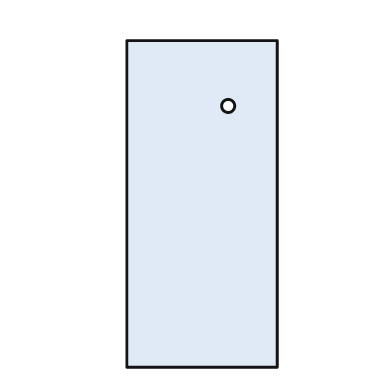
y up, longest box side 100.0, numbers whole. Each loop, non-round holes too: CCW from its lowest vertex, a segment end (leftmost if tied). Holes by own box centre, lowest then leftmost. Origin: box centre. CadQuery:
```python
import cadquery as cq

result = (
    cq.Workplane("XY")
    .moveTo(-23.0, -50.0)
    .lineTo(23.0, -50.0)
    .lineTo(23.0, 50.0)
    .lineTo(-23.0, 50.0)
    .close()
    .moveTo(8.0, 30.0)
    .circle(2.0)
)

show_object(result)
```